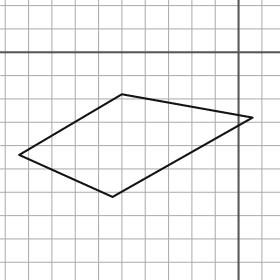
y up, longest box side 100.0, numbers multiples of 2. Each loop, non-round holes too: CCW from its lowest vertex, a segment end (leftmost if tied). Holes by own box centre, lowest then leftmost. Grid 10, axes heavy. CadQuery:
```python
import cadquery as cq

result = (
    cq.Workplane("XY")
    .moveTo(-54.0, -62.0)
    .lineTo(6.0, -28.0)
    .lineTo(-50.0, -18.0)
    .lineTo(-94.0, -44.0)
    .close()
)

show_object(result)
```